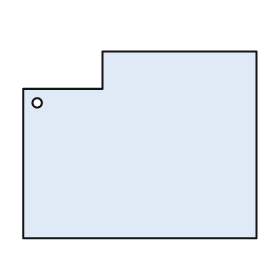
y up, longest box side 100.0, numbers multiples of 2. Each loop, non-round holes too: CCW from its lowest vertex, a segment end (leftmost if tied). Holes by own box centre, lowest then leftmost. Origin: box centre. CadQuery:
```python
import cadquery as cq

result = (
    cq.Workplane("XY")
    .moveTo(-50.0, -40.0)
    .lineTo(50.0, -40.0)
    .lineTo(50.0, 40.0)
    .lineTo(-16.0, 40.0)
    .lineTo(-16.0, 24.0)
    .lineTo(-50.0, 24.0)
    .close()
    .moveTo(-44.0, 18.0)
    .circle(2.0)
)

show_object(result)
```